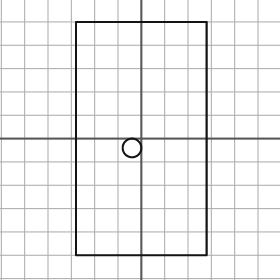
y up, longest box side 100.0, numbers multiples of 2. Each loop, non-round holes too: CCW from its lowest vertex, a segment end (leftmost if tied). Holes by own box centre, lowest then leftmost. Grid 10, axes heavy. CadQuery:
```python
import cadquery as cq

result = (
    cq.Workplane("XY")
    .moveTo(-28.0, -50.0)
    .lineTo(28.0, -50.0)
    .lineTo(28.0, 50.0)
    .lineTo(-28.0, 50.0)
    .close()
    .moveTo(-4.0, -4.0)
    .circle(4.0)
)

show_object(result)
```